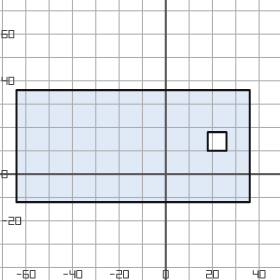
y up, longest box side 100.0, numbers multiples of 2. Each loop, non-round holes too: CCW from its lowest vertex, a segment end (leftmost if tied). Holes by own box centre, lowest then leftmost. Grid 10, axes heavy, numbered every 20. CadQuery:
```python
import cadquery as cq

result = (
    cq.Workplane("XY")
    .moveTo(-64.0, -12.0)
    .lineTo(36.0, -12.0)
    .lineTo(36.0, 36.0)
    .lineTo(-64.0, 36.0)
    .close()
    .moveTo(18.0, 10.0)
    .lineTo(26.0, 10.0)
    .lineTo(26.0, 18.0)
    .lineTo(18.0, 18.0)
    .close()
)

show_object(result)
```